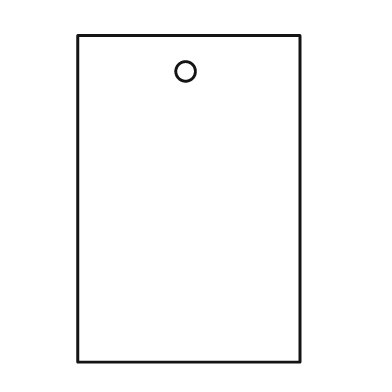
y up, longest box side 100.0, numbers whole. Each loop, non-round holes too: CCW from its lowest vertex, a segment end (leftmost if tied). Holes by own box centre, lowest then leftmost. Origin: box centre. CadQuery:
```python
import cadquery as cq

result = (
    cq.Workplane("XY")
    .moveTo(-34.0, -50.0)
    .lineTo(34.0, -50.0)
    .lineTo(34.0, 50.0)
    .lineTo(-34.0, 50.0)
    .close()
    .moveTo(-1.0, 39.0)
    .circle(3.0)
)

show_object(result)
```